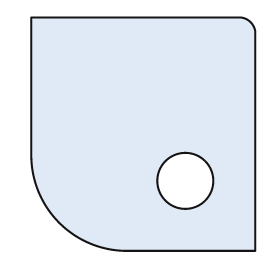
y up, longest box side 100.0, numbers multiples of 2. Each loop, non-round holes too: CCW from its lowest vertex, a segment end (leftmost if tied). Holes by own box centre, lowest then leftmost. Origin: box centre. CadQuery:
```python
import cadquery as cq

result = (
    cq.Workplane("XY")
    .moveTo(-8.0, -50.0)
    .lineTo(48.0, -50.0)
    .lineTo(48.0, 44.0)
    .threePointArc((46.0, 48.0), (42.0, 50.0))
    .lineTo(-48.0, 50.0)
    .lineTo(-48.0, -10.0)
    .threePointArc((-36.0, -38.0), (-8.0, -50.0))
    .close()
    .moveTo(18.0, -20.0)
    .circle(12.0)
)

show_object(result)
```